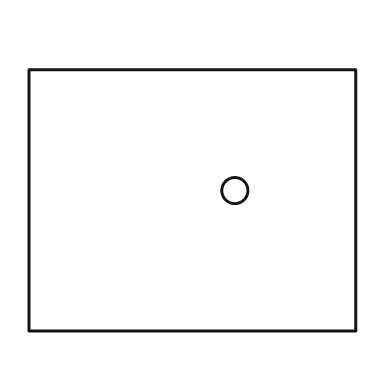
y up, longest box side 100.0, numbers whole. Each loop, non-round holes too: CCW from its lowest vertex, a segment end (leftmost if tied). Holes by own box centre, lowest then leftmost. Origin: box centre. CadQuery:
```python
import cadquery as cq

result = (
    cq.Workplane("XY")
    .moveTo(-50.0, -40.0)
    .lineTo(50.0, -40.0)
    .lineTo(50.0, 40.0)
    .lineTo(-50.0, 40.0)
    .close()
    .moveTo(13.0, 3.0)
    .circle(4.0)
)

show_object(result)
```